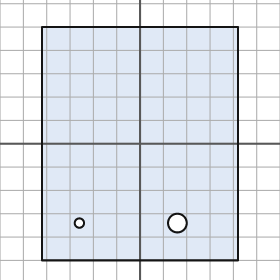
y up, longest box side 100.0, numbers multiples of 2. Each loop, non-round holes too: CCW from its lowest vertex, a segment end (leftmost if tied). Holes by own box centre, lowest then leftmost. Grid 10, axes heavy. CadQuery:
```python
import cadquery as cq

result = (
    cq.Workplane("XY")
    .moveTo(-42.0, -50.0)
    .lineTo(42.0, -50.0)
    .lineTo(42.0, 50.0)
    .lineTo(-42.0, 50.0)
    .close()
    .moveTo(-26.0, -34.0)
    .circle(2.0)
    .moveTo(16.0, -34.0)
    .circle(4.0)
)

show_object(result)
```